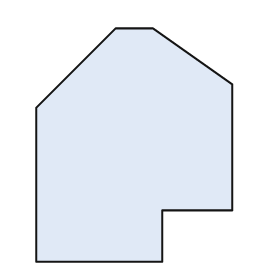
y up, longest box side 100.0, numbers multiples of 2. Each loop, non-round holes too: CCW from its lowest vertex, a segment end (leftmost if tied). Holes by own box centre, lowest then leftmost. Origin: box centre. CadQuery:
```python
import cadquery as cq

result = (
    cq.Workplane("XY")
    .moveTo(-42.0, -50.0)
    .lineTo(12.0, -50.0)
    .lineTo(12.0, -28.0)
    .lineTo(42.0, -28.0)
    .lineTo(42.0, 26.0)
    .lineTo(8.0, 50.0)
    .lineTo(-8.0, 50.0)
    .lineTo(-42.0, 16.0)
    .close()
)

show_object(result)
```